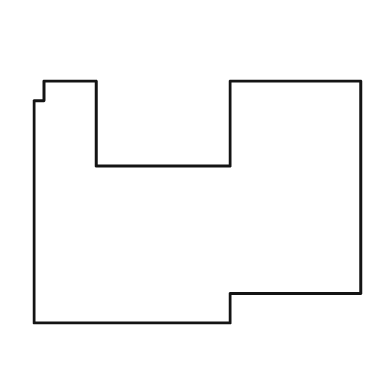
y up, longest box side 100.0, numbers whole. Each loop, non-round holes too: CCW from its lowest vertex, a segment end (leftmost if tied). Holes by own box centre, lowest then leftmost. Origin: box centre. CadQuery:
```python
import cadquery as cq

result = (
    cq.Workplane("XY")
    .moveTo(-50.0, -37.0)
    .lineTo(10.0, -37.0)
    .lineTo(10.0, -28.0)
    .lineTo(50.0, -28.0)
    .lineTo(50.0, 37.0)
    .lineTo(10.0, 37.0)
    .lineTo(10.0, 11.0)
    .lineTo(-31.0, 11.0)
    .lineTo(-31.0, 37.0)
    .lineTo(-47.0, 37.0)
    .lineTo(-47.0, 31.0)
    .lineTo(-50.0, 31.0)
    .close()
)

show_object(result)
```